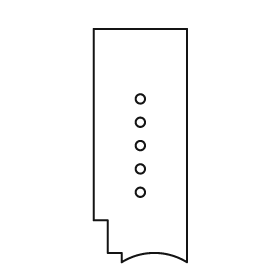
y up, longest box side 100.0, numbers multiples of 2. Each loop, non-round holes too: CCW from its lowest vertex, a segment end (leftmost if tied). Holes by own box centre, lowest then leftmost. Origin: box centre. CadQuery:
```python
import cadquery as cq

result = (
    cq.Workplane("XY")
    .moveTo(-8.0, -50.0)
    .threePointArc((6.0, -46.0), (20.0, -50.0))
    .lineTo(20.0, 50.0)
    .lineTo(-20.0, 50.0)
    .lineTo(-20.0, -32.0)
    .lineTo(-14.0, -32.0)
    .lineTo(-14.0, -46.0)
    .lineTo(-8.0, -46.0)
    .close()
    .moveTo(0.0, -20.0)
    .circle(2.0)
    .moveTo(0.0, -10.0)
    .circle(2.0)
    .moveTo(0.0, 0.0)
    .circle(2.0)
    .moveTo(0.0, 10.0)
    .circle(2.0)
    .moveTo(0.0, 20.0)
    .circle(2.0)
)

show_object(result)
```